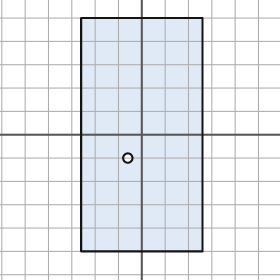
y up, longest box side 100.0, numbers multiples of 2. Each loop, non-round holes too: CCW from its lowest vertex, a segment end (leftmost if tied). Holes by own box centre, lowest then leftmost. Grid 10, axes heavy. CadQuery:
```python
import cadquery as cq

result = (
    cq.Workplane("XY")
    .moveTo(-26.0, -50.0)
    .lineTo(26.0, -50.0)
    .lineTo(26.0, 50.0)
    .lineTo(-26.0, 50.0)
    .close()
    .moveTo(-6.0, -10.0)
    .circle(2.0)
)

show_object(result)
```